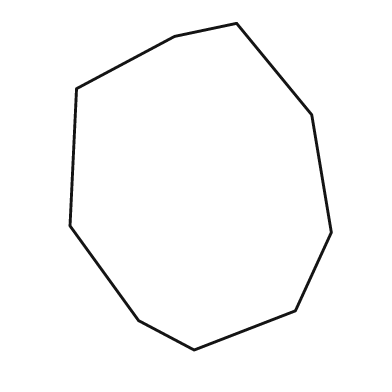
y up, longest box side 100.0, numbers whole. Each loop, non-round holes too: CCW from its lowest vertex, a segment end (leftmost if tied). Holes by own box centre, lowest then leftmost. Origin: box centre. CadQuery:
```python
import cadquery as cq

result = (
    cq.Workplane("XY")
    .moveTo(-2.0, -50.0)
    .lineTo(29.0, -38.0)
    .lineTo(40.0, -14.0)
    .lineTo(34.0, 22.0)
    .lineTo(11.0, 50.0)
    .lineTo(-8.0, 46.0)
    .lineTo(-38.0, 30.0)
    .lineTo(-40.0, -12.0)
    .lineTo(-19.0, -41.0)
    .close()
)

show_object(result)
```